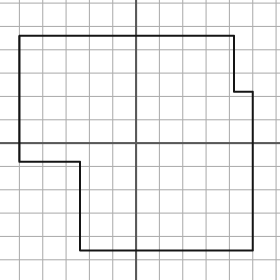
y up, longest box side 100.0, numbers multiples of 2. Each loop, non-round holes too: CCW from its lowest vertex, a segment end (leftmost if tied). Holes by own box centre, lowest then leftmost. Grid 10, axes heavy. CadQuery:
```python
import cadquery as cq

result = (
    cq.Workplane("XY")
    .moveTo(-24.0, -46.0)
    .lineTo(50.0, -46.0)
    .lineTo(50.0, 22.0)
    .lineTo(42.0, 22.0)
    .lineTo(42.0, 46.0)
    .lineTo(-50.0, 46.0)
    .lineTo(-50.0, -8.0)
    .lineTo(-24.0, -8.0)
    .close()
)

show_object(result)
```